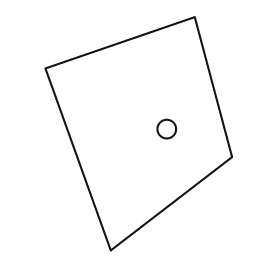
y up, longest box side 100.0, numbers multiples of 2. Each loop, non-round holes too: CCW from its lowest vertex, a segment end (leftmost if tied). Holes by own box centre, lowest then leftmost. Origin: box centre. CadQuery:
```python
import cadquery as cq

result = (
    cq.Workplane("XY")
    .moveTo(-12.0, -50.0)
    .lineTo(40.0, -10.0)
    .lineTo(24.0, 50.0)
    .lineTo(-40.0, 28.0)
    .close()
    .moveTo(12.0, 2.0)
    .circle(4.0)
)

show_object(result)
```